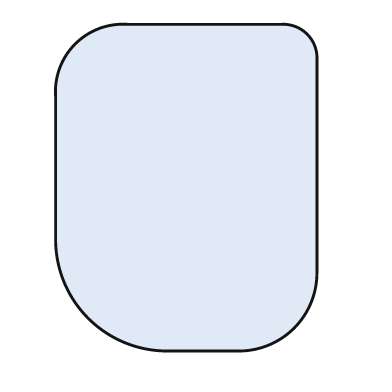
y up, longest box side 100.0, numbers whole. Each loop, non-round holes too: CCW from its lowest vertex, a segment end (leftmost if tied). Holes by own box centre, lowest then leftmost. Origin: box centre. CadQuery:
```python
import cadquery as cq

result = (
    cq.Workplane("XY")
    .moveTo(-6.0, -50.0)
    .lineTo(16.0, -50.0)
    .threePointArc((33.0, -43.0), (40.0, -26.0))
    .lineTo(40.0, 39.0)
    .threePointArc((37.0, 47.0), (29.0, 50.0))
    .lineTo(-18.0, 50.0)
    .threePointArc((-34.0, 44.0), (-40.0, 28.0))
    .lineTo(-40.0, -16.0)
    .threePointArc((-30.0, -40.0), (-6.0, -50.0))
    .close()
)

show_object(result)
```